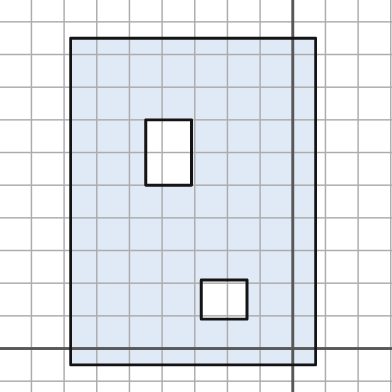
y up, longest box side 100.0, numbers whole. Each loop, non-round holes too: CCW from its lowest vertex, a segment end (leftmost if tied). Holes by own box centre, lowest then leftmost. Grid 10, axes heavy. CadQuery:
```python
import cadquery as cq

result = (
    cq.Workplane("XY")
    .moveTo(-68.0, -5.0)
    .lineTo(7.0, -5.0)
    .lineTo(7.0, 95.0)
    .lineTo(-68.0, 95.0)
    .close()
    .moveTo(-28.0, 9.0)
    .lineTo(-14.0, 9.0)
    .lineTo(-14.0, 21.0)
    .lineTo(-28.0, 21.0)
    .close()
    .moveTo(-45.0, 50.0)
    .lineTo(-31.0, 50.0)
    .lineTo(-31.0, 70.0)
    .lineTo(-45.0, 70.0)
    .close()
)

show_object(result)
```